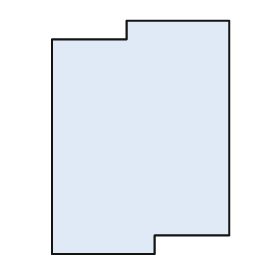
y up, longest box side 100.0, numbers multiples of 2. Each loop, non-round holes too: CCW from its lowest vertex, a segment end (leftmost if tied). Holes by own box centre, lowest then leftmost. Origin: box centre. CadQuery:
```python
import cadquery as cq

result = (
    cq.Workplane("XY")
    .moveTo(-38.0, -50.0)
    .lineTo(6.0, -50.0)
    .lineTo(6.0, -42.0)
    .lineTo(38.0, -42.0)
    .lineTo(38.0, 50.0)
    .lineTo(-6.0, 50.0)
    .lineTo(-6.0, 42.0)
    .lineTo(-38.0, 42.0)
    .close()
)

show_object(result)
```